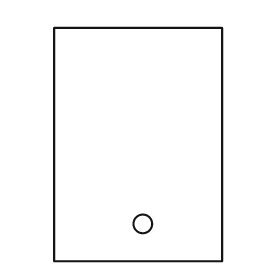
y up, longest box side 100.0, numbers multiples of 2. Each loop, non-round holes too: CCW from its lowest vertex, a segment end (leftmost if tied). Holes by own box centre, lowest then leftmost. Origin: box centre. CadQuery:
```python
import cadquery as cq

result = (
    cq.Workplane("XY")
    .moveTo(-36.0, -50.0)
    .lineTo(36.0, -50.0)
    .lineTo(36.0, 50.0)
    .lineTo(-36.0, 50.0)
    .close()
    .moveTo(2.0, -34.0)
    .circle(4.0)
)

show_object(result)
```